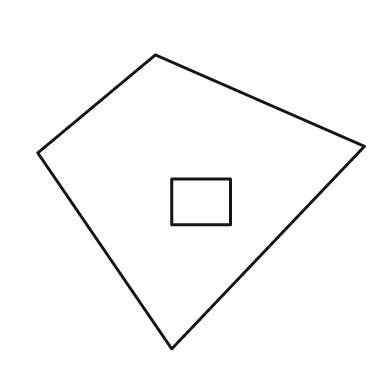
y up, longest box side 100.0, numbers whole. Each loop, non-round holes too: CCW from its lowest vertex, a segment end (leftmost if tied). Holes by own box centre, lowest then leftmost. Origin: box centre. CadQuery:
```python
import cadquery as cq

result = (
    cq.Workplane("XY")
    .moveTo(-9.0, -45.0)
    .lineTo(50.0, 17.0)
    .lineTo(-14.0, 45.0)
    .lineTo(-50.0, 15.0)
    .close()
    .moveTo(-9.0, -7.0)
    .lineTo(9.0, -7.0)
    .lineTo(9.0, 7.0)
    .lineTo(-9.0, 7.0)
    .close()
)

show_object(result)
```